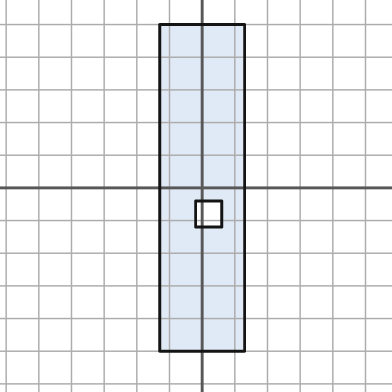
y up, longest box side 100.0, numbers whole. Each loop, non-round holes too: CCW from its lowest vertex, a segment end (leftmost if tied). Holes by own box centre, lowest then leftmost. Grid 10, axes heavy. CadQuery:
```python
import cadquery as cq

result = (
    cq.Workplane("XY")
    .moveTo(-13.0, -50.0)
    .lineTo(13.0, -50.0)
    .lineTo(13.0, 50.0)
    .lineTo(-13.0, 50.0)
    .close()
    .moveTo(-2.0, -12.0)
    .lineTo(6.0, -12.0)
    .lineTo(6.0, -4.0)
    .lineTo(-2.0, -4.0)
    .close()
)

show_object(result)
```